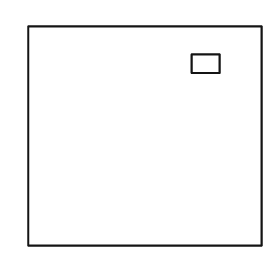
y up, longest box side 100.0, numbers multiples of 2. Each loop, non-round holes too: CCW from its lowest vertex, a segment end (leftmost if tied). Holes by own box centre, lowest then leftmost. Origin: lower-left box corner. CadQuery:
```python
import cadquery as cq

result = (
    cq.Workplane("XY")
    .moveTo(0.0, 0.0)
    .lineTo(100.0, 0.0)
    .lineTo(100.0, 94.0)
    .lineTo(0.0, 94.0)
    .close()
    .moveTo(70.0, 74.0)
    .lineTo(82.0, 74.0)
    .lineTo(82.0, 82.0)
    .lineTo(70.0, 82.0)
    .close()
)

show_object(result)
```